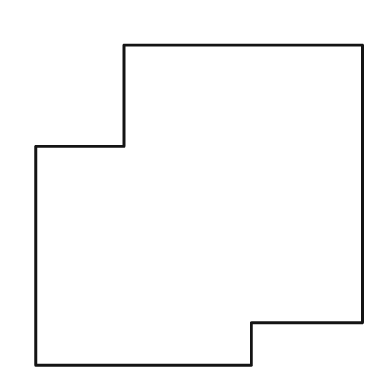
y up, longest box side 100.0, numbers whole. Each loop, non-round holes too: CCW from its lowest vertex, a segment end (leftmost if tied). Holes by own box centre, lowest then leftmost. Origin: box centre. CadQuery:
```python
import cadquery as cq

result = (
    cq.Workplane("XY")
    .moveTo(-50.0, -49.0)
    .lineTo(16.0, -49.0)
    .lineTo(16.0, -36.0)
    .lineTo(50.0, -36.0)
    .lineTo(50.0, 49.0)
    .lineTo(-23.0, 49.0)
    .lineTo(-23.0, 18.0)
    .lineTo(-50.0, 18.0)
    .close()
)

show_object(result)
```